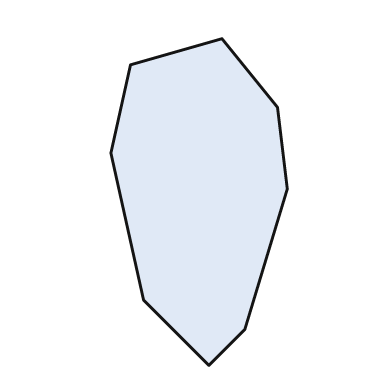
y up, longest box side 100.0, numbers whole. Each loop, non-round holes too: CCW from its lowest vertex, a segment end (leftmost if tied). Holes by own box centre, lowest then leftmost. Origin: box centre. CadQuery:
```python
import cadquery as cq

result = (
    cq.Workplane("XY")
    .moveTo(3.0, -50.0)
    .lineTo(14.0, -39.0)
    .lineTo(27.0, 4.0)
    .lineTo(24.0, 29.0)
    .lineTo(7.0, 50.0)
    .lineTo(-21.0, 42.0)
    .lineTo(-27.0, 15.0)
    .lineTo(-17.0, -30.0)
    .close()
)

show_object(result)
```